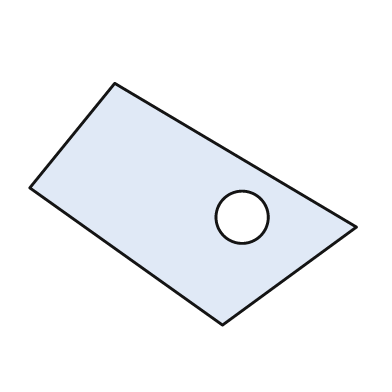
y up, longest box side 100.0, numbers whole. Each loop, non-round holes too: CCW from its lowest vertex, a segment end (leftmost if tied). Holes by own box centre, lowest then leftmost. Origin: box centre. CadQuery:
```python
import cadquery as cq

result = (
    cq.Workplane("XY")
    .moveTo(9.0, -37.0)
    .lineTo(50.0, -7.0)
    .lineTo(-24.0, 37.0)
    .lineTo(-50.0, 5.0)
    .close()
    .moveTo(15.0, -4.0)
    .circle(8.0)
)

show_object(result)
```